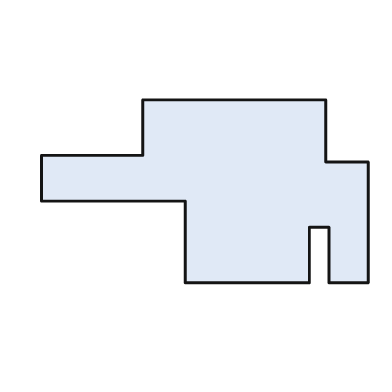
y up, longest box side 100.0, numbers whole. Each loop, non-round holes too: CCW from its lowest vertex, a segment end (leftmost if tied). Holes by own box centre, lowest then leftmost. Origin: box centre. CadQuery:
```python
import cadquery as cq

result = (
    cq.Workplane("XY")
    .moveTo(-6.0, -28.0)
    .lineTo(32.0, -28.0)
    .lineTo(32.0, -11.0)
    .lineTo(38.0, -11.0)
    .lineTo(38.0, -28.0)
    .lineTo(50.0, -28.0)
    .lineTo(50.0, 9.0)
    .lineTo(37.0, 9.0)
    .lineTo(37.0, 28.0)
    .lineTo(-19.0, 28.0)
    .lineTo(-19.0, 11.0)
    .lineTo(-50.0, 11.0)
    .lineTo(-50.0, -3.0)
    .lineTo(-6.0, -3.0)
    .close()
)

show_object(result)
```